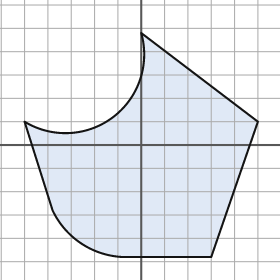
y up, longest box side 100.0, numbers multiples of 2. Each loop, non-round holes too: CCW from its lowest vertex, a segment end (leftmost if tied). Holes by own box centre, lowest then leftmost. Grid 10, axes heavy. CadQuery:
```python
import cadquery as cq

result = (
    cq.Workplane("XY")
    .moveTo(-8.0, -48.0)
    .lineTo(30.0, -48.0)
    .lineTo(50.0, 10.0)
    .lineTo(0.0, 48.0)
    .threePointArc((-12.0, 12.0), (-50.0, 10.0))
    .lineTo(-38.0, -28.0)
    .threePointArc((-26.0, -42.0), (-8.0, -48.0))
    .close()
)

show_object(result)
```